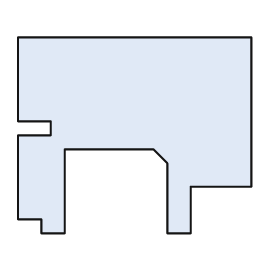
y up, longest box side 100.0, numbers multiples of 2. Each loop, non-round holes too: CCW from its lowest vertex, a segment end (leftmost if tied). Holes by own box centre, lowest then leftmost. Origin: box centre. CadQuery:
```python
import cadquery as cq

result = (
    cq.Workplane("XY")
    .moveTo(-40.0, -42.0)
    .lineTo(-30.0, -42.0)
    .lineTo(-30.0, -6.0)
    .lineTo(8.0, -6.0)
    .lineTo(14.0, -12.0)
    .lineTo(14.0, -42.0)
    .lineTo(24.0, -42.0)
    .lineTo(24.0, -22.0)
    .lineTo(50.0, -22.0)
    .lineTo(50.0, 42.0)
    .lineTo(-50.0, 42.0)
    .lineTo(-50.0, 6.0)
    .lineTo(-36.0, 6.0)
    .lineTo(-36.0, 0.0)
    .lineTo(-50.0, 0.0)
    .lineTo(-50.0, -36.0)
    .lineTo(-40.0, -36.0)
    .close()
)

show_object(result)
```